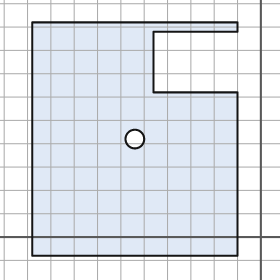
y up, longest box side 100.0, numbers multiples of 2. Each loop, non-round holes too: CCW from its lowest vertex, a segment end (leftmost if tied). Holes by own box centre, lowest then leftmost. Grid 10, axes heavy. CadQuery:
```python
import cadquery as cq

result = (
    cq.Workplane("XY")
    .moveTo(-98.0, -8.0)
    .lineTo(-10.0, -8.0)
    .lineTo(-10.0, 62.0)
    .lineTo(-46.0, 62.0)
    .lineTo(-46.0, 88.0)
    .lineTo(-10.0, 88.0)
    .lineTo(-10.0, 92.0)
    .lineTo(-98.0, 92.0)
    .close()
    .moveTo(-54.0, 42.0)
    .circle(4.0)
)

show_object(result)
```